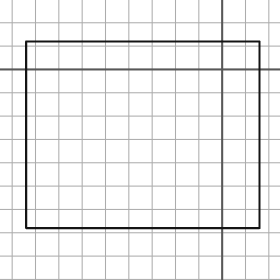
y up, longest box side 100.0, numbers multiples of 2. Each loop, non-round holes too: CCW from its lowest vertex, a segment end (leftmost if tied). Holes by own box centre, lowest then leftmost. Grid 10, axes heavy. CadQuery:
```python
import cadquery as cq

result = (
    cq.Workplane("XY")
    .moveTo(-84.0, -68.0)
    .lineTo(16.0, -68.0)
    .lineTo(16.0, 12.0)
    .lineTo(-84.0, 12.0)
    .close()
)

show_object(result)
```